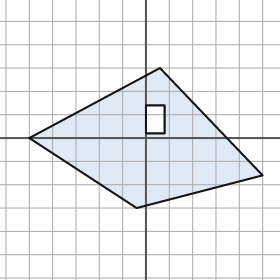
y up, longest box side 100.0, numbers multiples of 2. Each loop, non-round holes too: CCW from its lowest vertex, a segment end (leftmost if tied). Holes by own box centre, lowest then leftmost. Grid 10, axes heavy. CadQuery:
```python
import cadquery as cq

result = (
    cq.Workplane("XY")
    .moveTo(-4.0, -30.0)
    .lineTo(50.0, -16.0)
    .lineTo(6.0, 30.0)
    .lineTo(-50.0, 0.0)
    .close()
    .moveTo(0.0, 2.0)
    .lineTo(8.0, 2.0)
    .lineTo(8.0, 14.0)
    .lineTo(0.0, 14.0)
    .close()
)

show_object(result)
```